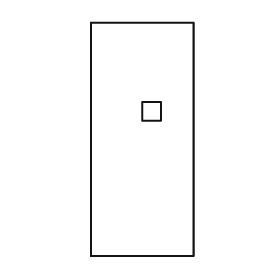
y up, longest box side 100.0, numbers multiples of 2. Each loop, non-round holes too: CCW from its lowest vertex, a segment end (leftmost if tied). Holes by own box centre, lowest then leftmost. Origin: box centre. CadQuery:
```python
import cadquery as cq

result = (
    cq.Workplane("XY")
    .moveTo(-22.0, -50.0)
    .lineTo(22.0, -50.0)
    .lineTo(22.0, 50.0)
    .lineTo(-22.0, 50.0)
    .close()
    .moveTo(0.0, 8.0)
    .lineTo(8.0, 8.0)
    .lineTo(8.0, 16.0)
    .lineTo(0.0, 16.0)
    .close()
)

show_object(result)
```